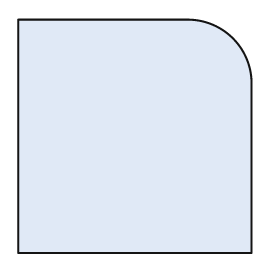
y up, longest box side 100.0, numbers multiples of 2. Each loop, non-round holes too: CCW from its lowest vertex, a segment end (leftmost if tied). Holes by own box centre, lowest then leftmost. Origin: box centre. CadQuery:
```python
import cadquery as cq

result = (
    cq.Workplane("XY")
    .moveTo(-50.0, -50.0)
    .lineTo(50.0, -50.0)
    .lineTo(50.0, 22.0)
    .threePointArc((42.0, 42.0), (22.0, 50.0))
    .lineTo(-50.0, 50.0)
    .close()
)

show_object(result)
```